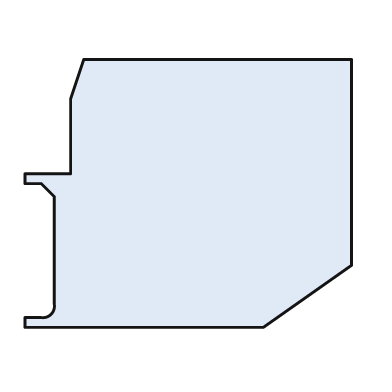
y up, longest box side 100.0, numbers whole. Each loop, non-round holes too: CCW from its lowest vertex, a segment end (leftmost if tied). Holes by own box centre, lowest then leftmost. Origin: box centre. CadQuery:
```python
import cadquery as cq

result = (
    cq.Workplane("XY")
    .moveTo(-50.0, -41.0)
    .lineTo(23.0, -41.0)
    .lineTo(50.0, -22.0)
    .lineTo(50.0, 41.0)
    .lineTo(-32.0, 41.0)
    .lineTo(-36.0, 29.0)
    .lineTo(-36.0, 6.0)
    .lineTo(-50.0, 6.0)
    .lineTo(-50.0, 3.0)
    .lineTo(-45.0, 3.0)
    .lineTo(-41.0, -1.0)
    .lineTo(-41.0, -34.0)
    .threePointArc((-42.0, -37.0), (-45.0, -38.0))
    .lineTo(-50.0, -38.0)
    .close()
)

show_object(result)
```